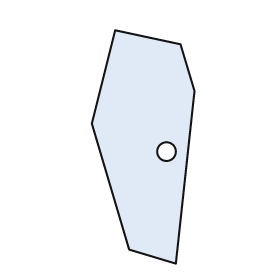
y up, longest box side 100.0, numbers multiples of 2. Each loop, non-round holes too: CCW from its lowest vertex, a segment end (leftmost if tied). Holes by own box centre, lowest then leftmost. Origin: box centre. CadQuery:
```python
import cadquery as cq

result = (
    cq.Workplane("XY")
    .moveTo(14.0, -50.0)
    .lineTo(22.0, 24.0)
    .lineTo(16.0, 44.0)
    .lineTo(-12.0, 50.0)
    .lineTo(-22.0, 10.0)
    .lineTo(-6.0, -44.0)
    .close()
    .moveTo(10.0, -2.0)
    .circle(4.0)
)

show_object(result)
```